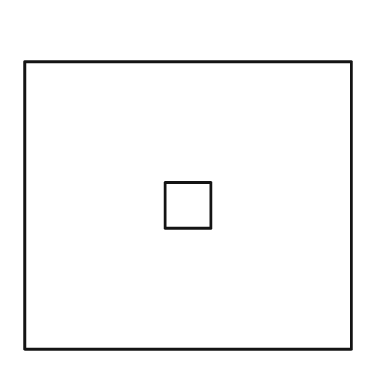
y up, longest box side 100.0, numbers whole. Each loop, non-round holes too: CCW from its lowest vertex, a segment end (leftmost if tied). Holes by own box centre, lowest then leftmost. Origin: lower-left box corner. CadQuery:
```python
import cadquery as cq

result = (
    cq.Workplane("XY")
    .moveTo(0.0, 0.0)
    .lineTo(100.0, 0.0)
    .lineTo(100.0, 88.0)
    .lineTo(0.0, 88.0)
    .close()
    .moveTo(43.0, 37.0)
    .lineTo(57.0, 37.0)
    .lineTo(57.0, 51.0)
    .lineTo(43.0, 51.0)
    .close()
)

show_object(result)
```